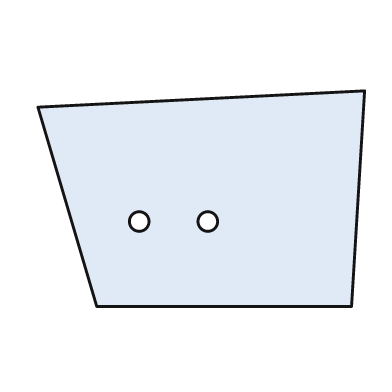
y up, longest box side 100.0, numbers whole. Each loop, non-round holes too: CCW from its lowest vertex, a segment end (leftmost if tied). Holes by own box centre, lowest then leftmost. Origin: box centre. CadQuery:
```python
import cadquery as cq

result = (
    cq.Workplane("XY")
    .moveTo(-32.0, -33.0)
    .lineTo(46.0, -33.0)
    .lineTo(50.0, 33.0)
    .lineTo(-50.0, 28.0)
    .close()
    .moveTo(-19.0, -7.0)
    .circle(3.0)
    .moveTo(2.0, -7.0)
    .circle(3.0)
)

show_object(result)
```